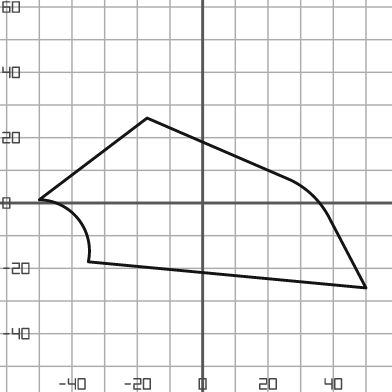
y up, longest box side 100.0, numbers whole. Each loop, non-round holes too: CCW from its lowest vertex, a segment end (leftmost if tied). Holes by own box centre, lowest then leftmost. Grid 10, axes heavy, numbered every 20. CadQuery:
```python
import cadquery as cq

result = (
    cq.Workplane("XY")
    .moveTo(50.0, -26.0)
    .lineTo(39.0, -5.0)
    .threePointArc((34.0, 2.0), (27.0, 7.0))
    .lineTo(-17.0, 26.0)
    .lineTo(-50.0, 1.0)
    .threePointArc((-38.0, -5.0), (-35.0, -18.0))
    .close()
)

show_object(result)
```